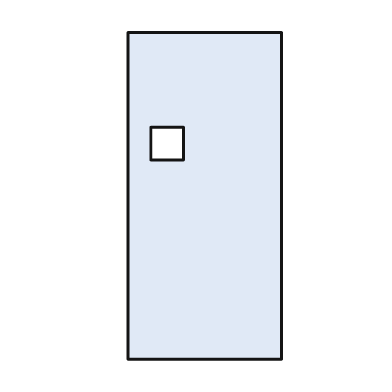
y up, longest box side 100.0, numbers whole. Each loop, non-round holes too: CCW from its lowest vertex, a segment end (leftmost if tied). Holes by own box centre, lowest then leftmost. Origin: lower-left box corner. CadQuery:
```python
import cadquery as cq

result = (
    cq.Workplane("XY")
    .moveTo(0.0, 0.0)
    .lineTo(47.0, 0.0)
    .lineTo(47.0, 100.0)
    .lineTo(0.0, 100.0)
    .close()
    .moveTo(7.0, 61.0)
    .lineTo(17.0, 61.0)
    .lineTo(17.0, 71.0)
    .lineTo(7.0, 71.0)
    .close()
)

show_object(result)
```